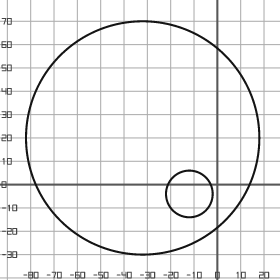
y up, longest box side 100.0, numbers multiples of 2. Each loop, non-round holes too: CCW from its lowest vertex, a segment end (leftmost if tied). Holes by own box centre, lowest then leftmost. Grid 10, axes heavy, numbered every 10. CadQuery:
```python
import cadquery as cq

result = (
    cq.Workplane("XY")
    .moveTo(-32.0, 20.0)
    .circle(50.0)
    .moveTo(-12.0, -4.0)
    .circle(10.0)
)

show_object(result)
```